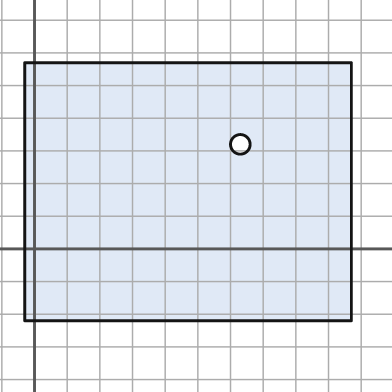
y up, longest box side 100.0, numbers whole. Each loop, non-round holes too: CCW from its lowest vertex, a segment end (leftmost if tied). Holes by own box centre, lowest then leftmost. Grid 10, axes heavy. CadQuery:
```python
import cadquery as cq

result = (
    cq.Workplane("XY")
    .moveTo(-3.0, -22.0)
    .lineTo(97.0, -22.0)
    .lineTo(97.0, 57.0)
    .lineTo(-3.0, 57.0)
    .close()
    .moveTo(63.0, 32.0)
    .circle(3.0)
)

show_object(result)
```